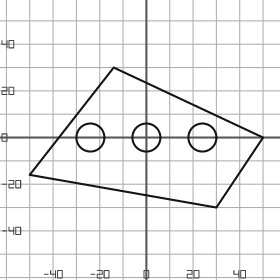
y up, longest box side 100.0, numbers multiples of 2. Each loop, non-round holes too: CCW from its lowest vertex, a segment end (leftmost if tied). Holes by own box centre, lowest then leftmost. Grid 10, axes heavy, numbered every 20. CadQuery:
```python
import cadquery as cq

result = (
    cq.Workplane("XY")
    .moveTo(30.0, -30.0)
    .lineTo(50.0, 0.0)
    .lineTo(-14.0, 30.0)
    .lineTo(-50.0, -16.0)
    .close()
    .moveTo(-24.0, 0.0)
    .circle(6.0)
    .moveTo(0.0, 0.0)
    .circle(6.0)
    .moveTo(24.0, 0.0)
    .circle(6.0)
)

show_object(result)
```